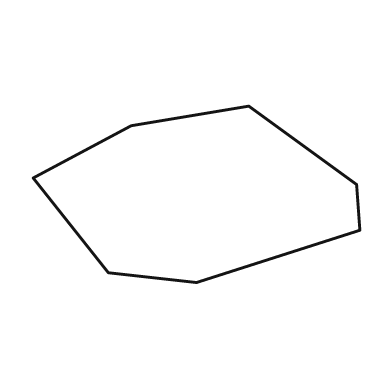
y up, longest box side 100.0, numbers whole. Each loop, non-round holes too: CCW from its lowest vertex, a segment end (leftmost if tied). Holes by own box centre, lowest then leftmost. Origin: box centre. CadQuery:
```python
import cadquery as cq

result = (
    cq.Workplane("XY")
    .moveTo(0.0, -27.0)
    .lineTo(50.0, -11.0)
    .lineTo(49.0, 3.0)
    .lineTo(16.0, 27.0)
    .lineTo(-20.0, 21.0)
    .lineTo(-50.0, 5.0)
    .lineTo(-27.0, -24.0)
    .close()
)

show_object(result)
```